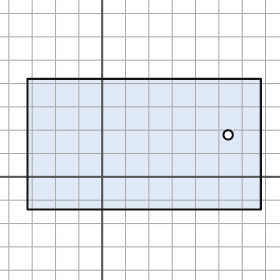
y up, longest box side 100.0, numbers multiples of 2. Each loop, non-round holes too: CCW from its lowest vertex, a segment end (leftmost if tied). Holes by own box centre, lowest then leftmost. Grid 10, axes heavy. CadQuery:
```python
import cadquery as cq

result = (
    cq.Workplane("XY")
    .moveTo(-32.0, -14.0)
    .lineTo(68.0, -14.0)
    .lineTo(68.0, 42.0)
    .lineTo(-32.0, 42.0)
    .close()
    .moveTo(54.0, 18.0)
    .circle(2.0)
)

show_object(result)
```